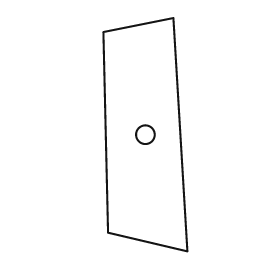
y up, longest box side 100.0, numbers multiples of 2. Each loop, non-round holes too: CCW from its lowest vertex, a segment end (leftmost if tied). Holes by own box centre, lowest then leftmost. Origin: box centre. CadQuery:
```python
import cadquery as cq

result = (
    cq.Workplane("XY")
    .moveTo(18.0, -50.0)
    .lineTo(12.0, 50.0)
    .lineTo(-18.0, 44.0)
    .lineTo(-16.0, -42.0)
    .close()
    .moveTo(0.0, 0.0)
    .circle(4.0)
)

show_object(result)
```